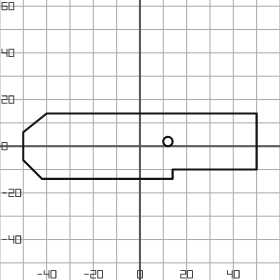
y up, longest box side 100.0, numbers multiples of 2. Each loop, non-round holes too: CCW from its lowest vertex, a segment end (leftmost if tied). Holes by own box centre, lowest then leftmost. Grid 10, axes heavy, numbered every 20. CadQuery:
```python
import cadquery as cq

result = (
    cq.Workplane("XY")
    .moveTo(-42.0, -14.0)
    .lineTo(14.0, -14.0)
    .lineTo(14.0, -10.0)
    .lineTo(50.0, -10.0)
    .lineTo(50.0, 14.0)
    .lineTo(-40.0, 14.0)
    .lineTo(-50.0, 6.0)
    .lineTo(-50.0, -6.0)
    .close()
    .moveTo(12.0, 2.0)
    .circle(2.0)
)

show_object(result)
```